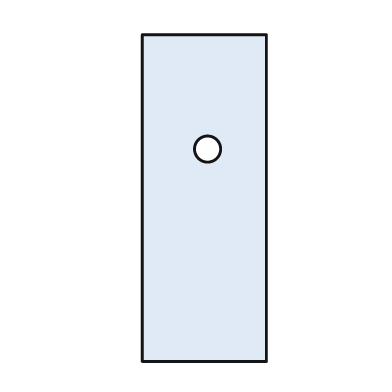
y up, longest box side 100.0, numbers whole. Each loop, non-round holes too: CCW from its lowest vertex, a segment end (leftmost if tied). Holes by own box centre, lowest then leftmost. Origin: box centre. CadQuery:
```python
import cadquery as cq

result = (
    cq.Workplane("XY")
    .moveTo(-19.0, -50.0)
    .lineTo(19.0, -50.0)
    .lineTo(19.0, 50.0)
    .lineTo(-19.0, 50.0)
    .close()
    .moveTo(1.0, 15.0)
    .circle(4.0)
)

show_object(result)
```